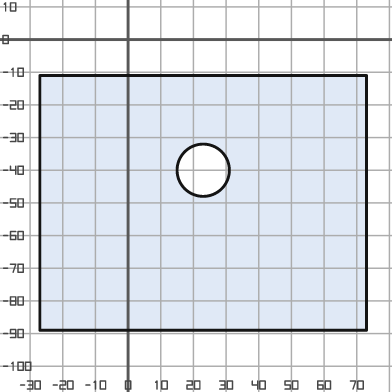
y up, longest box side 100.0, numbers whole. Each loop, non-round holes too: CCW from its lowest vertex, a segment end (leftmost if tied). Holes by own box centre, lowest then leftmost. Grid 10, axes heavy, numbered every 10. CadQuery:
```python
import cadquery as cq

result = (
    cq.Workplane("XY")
    .moveTo(-27.0, -89.0)
    .lineTo(73.0, -89.0)
    .lineTo(73.0, -11.0)
    .lineTo(-27.0, -11.0)
    .close()
    .moveTo(23.0, -40.0)
    .circle(8.0)
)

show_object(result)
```